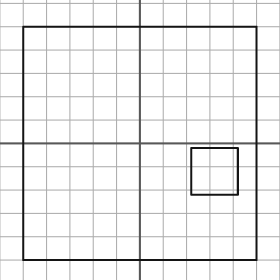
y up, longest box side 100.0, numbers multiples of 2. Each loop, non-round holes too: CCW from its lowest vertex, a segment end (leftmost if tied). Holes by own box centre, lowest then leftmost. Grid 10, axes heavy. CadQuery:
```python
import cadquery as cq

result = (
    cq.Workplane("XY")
    .moveTo(-50.0, -50.0)
    .lineTo(50.0, -50.0)
    .lineTo(50.0, 50.0)
    .lineTo(-50.0, 50.0)
    .close()
    .moveTo(22.0, -22.0)
    .lineTo(42.0, -22.0)
    .lineTo(42.0, -2.0)
    .lineTo(22.0, -2.0)
    .close()
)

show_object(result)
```